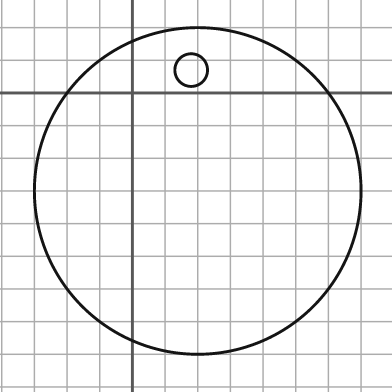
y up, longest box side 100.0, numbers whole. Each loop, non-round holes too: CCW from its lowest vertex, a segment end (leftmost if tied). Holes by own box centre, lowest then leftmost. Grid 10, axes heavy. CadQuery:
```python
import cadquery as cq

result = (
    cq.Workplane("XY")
    .moveTo(20.0, -30.0)
    .circle(50.0)
    .moveTo(18.0, 7.0)
    .circle(5.0)
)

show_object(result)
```